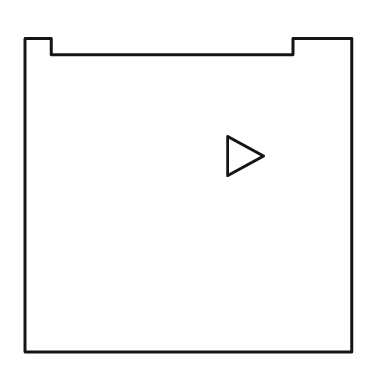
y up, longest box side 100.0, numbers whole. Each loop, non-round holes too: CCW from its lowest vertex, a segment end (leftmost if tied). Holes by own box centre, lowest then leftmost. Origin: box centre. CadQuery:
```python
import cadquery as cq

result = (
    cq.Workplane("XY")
    .moveTo(-50.0, -48.0)
    .lineTo(50.0, -48.0)
    .lineTo(50.0, 48.0)
    .lineTo(32.0, 48.0)
    .lineTo(32.0, 43.0)
    .lineTo(-42.0, 43.0)
    .lineTo(-42.0, 48.0)
    .lineTo(-50.0, 48.0)
    .close()
    .moveTo(12.0, 6.0)
    .lineTo(23.0, 12.0)
    .lineTo(12.0, 18.0)
    .close()
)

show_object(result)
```